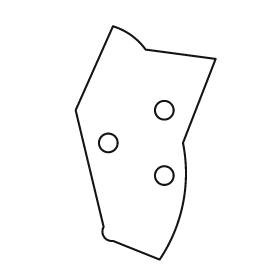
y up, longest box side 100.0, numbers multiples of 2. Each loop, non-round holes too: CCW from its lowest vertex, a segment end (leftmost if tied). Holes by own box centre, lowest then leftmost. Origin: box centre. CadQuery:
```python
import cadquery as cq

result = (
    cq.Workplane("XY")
    .moveTo(6.0, -50.0)
    .threePointArc((16.0, -26.0), (16.0, 0.0))
    .lineTo(30.0, 36.0)
    .lineTo(0.0, 40.0)
    .threePointArc((-6.0, 46.0), (-14.0, 50.0))
    .lineTo(-30.0, 14.0)
    .lineTo(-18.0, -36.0)
    .threePointArc((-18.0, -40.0), (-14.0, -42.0))
    .close()
    .moveTo(8.0, -14.0)
    .circle(4.0)
    .moveTo(-16.0, 0.0)
    .circle(4.0)
    .moveTo(8.0, 14.0)
    .circle(4.0)
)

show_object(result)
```